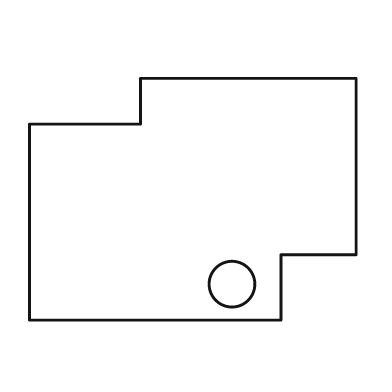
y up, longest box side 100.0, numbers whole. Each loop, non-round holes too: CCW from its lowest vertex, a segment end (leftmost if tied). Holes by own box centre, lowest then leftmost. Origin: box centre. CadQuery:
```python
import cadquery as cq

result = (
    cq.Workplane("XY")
    .moveTo(-50.0, -37.0)
    .lineTo(27.0, -37.0)
    .lineTo(27.0, -17.0)
    .lineTo(50.0, -17.0)
    .lineTo(50.0, 37.0)
    .lineTo(-16.0, 37.0)
    .lineTo(-16.0, 23.0)
    .lineTo(-50.0, 23.0)
    .close()
    .moveTo(12.0, -26.0)
    .circle(7.0)
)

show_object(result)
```